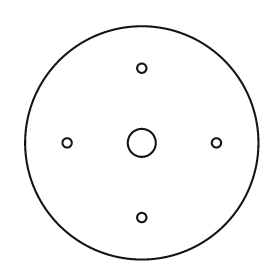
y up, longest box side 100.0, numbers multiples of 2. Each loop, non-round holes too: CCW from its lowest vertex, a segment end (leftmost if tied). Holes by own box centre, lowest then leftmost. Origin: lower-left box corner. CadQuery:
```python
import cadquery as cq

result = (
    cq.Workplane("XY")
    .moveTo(50.0, 50.0)
    .circle(50.0)
    .moveTo(50.0, 18.0)
    .circle(2.0)
    .moveTo(18.0, 50.0)
    .circle(2.0)
    .moveTo(50.0, 50.0)
    .circle(6.0)
    .moveTo(82.0, 50.0)
    .circle(2.0)
    .moveTo(50.0, 82.0)
    .circle(2.0)
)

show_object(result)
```